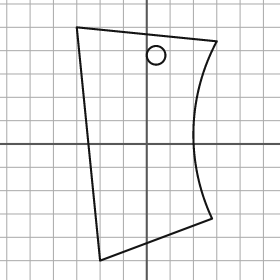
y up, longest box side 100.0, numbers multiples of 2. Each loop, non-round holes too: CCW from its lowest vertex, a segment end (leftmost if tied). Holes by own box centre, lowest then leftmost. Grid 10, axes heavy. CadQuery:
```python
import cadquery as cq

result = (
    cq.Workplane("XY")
    .moveTo(-20.0, -50.0)
    .lineTo(28.0, -32.0)
    .threePointArc((20.0, 6.0), (30.0, 44.0))
    .lineTo(-30.0, 50.0)
    .close()
    .moveTo(4.0, 38.0)
    .circle(4.0)
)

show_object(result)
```